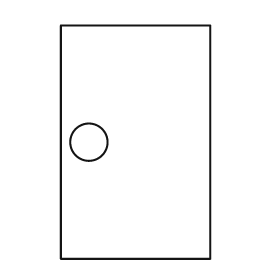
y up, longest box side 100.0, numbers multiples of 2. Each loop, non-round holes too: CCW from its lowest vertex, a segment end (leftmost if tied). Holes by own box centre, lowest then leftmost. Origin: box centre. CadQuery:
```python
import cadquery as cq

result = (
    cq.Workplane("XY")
    .moveTo(-32.0, -50.0)
    .lineTo(32.0, -50.0)
    .lineTo(32.0, 50.0)
    .lineTo(-32.0, 50.0)
    .close()
    .moveTo(-20.0, 0.0)
    .circle(8.0)
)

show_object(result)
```